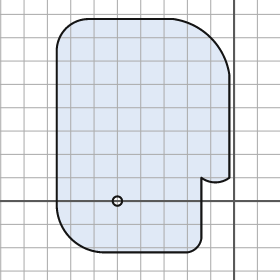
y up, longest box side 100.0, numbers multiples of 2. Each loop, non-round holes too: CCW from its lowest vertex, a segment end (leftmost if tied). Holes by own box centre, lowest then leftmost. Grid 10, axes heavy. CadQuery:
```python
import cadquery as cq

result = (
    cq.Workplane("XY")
    .moveTo(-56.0, -22.0)
    .lineTo(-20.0, -22.0)
    .threePointArc((-16.0, -20.0), (-14.0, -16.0))
    .lineTo(-14.0, 10.0)
    .threePointArc((-8.0, 8.0), (-2.0, 10.0))
    .lineTo(-2.0, 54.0)
    .threePointArc((-10.0, 70.0), (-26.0, 78.0))
    .lineTo(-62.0, 78.0)
    .threePointArc((-72.0, 74.0), (-76.0, 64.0))
    .lineTo(-76.0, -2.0)
    .threePointArc((-70.0, -16.0), (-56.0, -22.0))
    .close()
    .moveTo(-50.0, 0.0)
    .circle(2.0)
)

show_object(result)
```